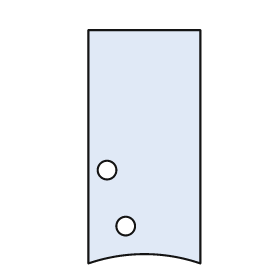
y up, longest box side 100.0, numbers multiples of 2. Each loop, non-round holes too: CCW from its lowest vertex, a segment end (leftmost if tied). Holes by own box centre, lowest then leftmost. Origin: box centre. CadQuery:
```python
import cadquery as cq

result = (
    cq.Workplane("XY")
    .moveTo(-24.0, -50.0)
    .threePointArc((0.0, -46.0), (24.0, -50.0))
    .lineTo(24.0, 50.0)
    .lineTo(-24.0, 50.0)
    .close()
    .moveTo(-8.0, -34.0)
    .circle(4.0)
    .moveTo(-16.0, -10.0)
    .circle(4.0)
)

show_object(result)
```